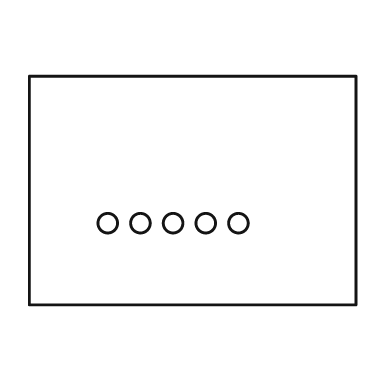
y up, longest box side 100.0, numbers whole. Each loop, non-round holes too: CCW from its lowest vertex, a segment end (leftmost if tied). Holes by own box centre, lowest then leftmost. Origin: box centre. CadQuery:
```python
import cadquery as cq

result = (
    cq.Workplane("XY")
    .moveTo(-50.0, -35.0)
    .lineTo(50.0, -35.0)
    .lineTo(50.0, 35.0)
    .lineTo(-50.0, 35.0)
    .close()
    .moveTo(-26.0, -10.0)
    .circle(3.0)
    .moveTo(-16.0, -10.0)
    .circle(3.0)
    .moveTo(-6.0, -10.0)
    .circle(3.0)
    .moveTo(4.0, -10.0)
    .circle(3.0)
    .moveTo(14.0, -10.0)
    .circle(3.0)
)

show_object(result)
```